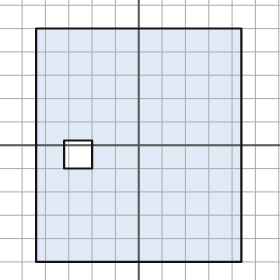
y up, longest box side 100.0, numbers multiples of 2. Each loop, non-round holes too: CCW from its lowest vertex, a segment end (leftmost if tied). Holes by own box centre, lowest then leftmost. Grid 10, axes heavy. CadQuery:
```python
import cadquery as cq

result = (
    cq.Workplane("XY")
    .moveTo(-44.0, -50.0)
    .lineTo(44.0, -50.0)
    .lineTo(44.0, 50.0)
    .lineTo(-44.0, 50.0)
    .close()
    .moveTo(-32.0, -10.0)
    .lineTo(-20.0, -10.0)
    .lineTo(-20.0, 2.0)
    .lineTo(-32.0, 2.0)
    .close()
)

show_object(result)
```